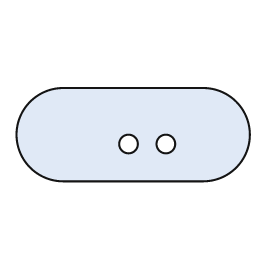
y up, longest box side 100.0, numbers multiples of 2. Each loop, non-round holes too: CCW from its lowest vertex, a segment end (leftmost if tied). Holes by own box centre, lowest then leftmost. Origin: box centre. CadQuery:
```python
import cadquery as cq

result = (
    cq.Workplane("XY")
    .moveTo(-30.0, -20.0)
    .lineTo(30.0, -20.0)
    .threePointArc((50.0, 0.0), (30.0, 20.0))
    .lineTo(-30.0, 20.0)
    .threePointArc((-50.0, 0.0), (-30.0, -20.0))
    .close()
    .moveTo(-2.0, -4.0)
    .circle(4.0)
    .moveTo(14.0, -4.0)
    .circle(4.0)
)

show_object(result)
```